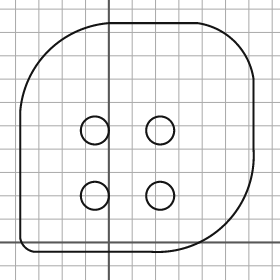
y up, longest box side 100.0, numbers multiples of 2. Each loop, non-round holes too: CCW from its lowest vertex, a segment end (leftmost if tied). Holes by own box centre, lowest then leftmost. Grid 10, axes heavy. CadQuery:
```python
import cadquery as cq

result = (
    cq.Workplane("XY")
    .moveTo(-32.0, -4.0)
    .lineTo(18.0, -4.0)
    .threePointArc((50.0, 8.0), (62.0, 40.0))
    .lineTo(62.0, 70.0)
    .threePointArc((54.0, 86.0), (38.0, 94.0))
    .lineTo(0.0, 94.0)
    .threePointArc((-26.0, 82.0), (-38.0, 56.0))
    .lineTo(-38.0, 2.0)
    .threePointArc((-36.0, -2.0), (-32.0, -4.0))
    .close()
    .moveTo(-6.0, 20.0)
    .circle(6.0)
    .moveTo(22.0, 20.0)
    .circle(6.0)
    .moveTo(-6.0, 48.0)
    .circle(6.0)
    .moveTo(22.0, 48.0)
    .circle(6.0)
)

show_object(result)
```